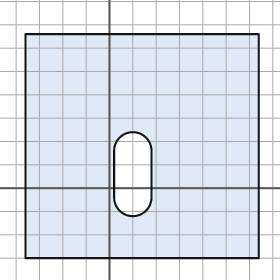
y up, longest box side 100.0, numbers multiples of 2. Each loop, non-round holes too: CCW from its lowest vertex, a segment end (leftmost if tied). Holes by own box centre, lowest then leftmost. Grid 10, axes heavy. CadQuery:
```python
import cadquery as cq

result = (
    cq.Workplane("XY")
    .moveTo(-36.0, -30.0)
    .lineTo(64.0, -30.0)
    .lineTo(64.0, 66.0)
    .lineTo(-36.0, 66.0)
    .close()
    .moveTo(2.0, -4.0)
    .threePointArc((10.0, -12.0), (18.0, -4.0))
    .lineTo(18.0, 16.0)
    .threePointArc((10.0, 24.0), (2.0, 16.0))
    .close()
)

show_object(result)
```